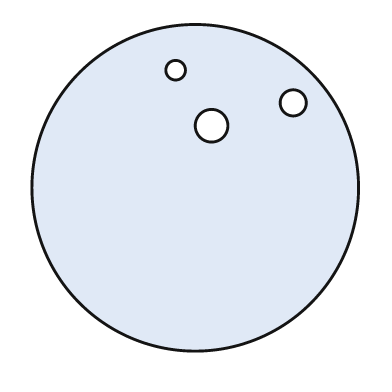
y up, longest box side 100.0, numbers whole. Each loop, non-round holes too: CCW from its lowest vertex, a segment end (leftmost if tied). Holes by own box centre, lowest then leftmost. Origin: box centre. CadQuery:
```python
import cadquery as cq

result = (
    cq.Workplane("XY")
    .moveTo(0.0, 0.0)
    .circle(50.0)
    .moveTo(5.0, 19.0)
    .circle(5.0)
    .moveTo(30.0, 26.0)
    .circle(4.0)
    .moveTo(-6.0, 36.0)
    .circle(3.0)
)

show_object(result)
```